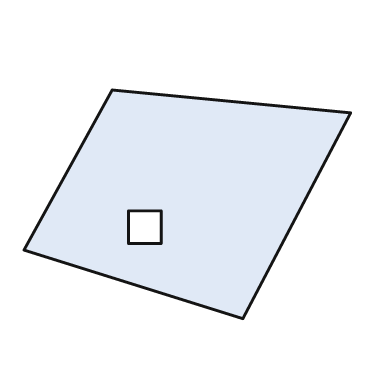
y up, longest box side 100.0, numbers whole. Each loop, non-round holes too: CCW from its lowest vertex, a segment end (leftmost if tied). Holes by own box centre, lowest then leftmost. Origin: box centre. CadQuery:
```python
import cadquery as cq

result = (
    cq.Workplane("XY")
    .moveTo(17.0, -35.0)
    .lineTo(50.0, 28.0)
    .lineTo(-23.0, 35.0)
    .lineTo(-50.0, -14.0)
    .close()
    .moveTo(-18.0, -12.0)
    .lineTo(-8.0, -12.0)
    .lineTo(-8.0, -2.0)
    .lineTo(-18.0, -2.0)
    .close()
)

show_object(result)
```